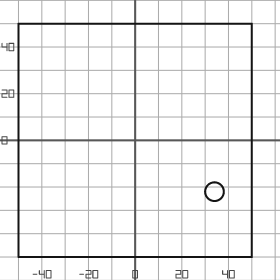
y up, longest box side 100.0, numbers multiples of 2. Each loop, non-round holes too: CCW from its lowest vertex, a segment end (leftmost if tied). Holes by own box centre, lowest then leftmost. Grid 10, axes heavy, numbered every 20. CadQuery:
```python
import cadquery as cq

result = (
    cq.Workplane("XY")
    .moveTo(-50.0, -50.0)
    .lineTo(50.0, -50.0)
    .lineTo(50.0, 50.0)
    .lineTo(-50.0, 50.0)
    .close()
    .moveTo(34.0, -22.0)
    .circle(4.0)
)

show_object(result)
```